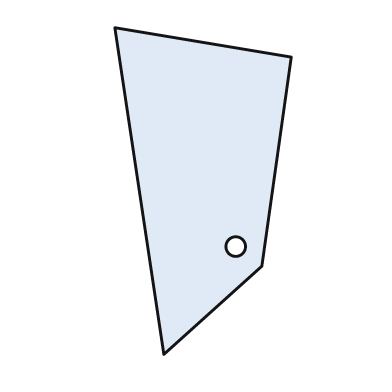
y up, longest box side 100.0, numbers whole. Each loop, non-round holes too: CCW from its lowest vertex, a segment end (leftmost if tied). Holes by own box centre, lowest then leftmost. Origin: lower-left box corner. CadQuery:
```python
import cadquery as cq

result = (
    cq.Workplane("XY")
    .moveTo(15.0, 0.0)
    .lineTo(45.0, 27.0)
    .lineTo(54.0, 91.0)
    .lineTo(0.0, 100.0)
    .close()
    .moveTo(37.0, 33.0)
    .circle(3.0)
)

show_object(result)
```